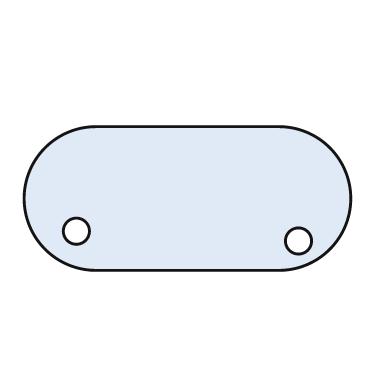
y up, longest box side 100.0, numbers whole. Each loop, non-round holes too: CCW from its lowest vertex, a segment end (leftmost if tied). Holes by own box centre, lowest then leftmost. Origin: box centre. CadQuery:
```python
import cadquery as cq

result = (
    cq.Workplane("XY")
    .moveTo(-28.0, -22.0)
    .lineTo(28.0, -22.0)
    .threePointArc((50.0, 0.0), (28.0, 22.0))
    .lineTo(-28.0, 22.0)
    .threePointArc((-50.0, 0.0), (-28.0, -22.0))
    .close()
    .moveTo(34.0, -13.0)
    .circle(4.0)
    .moveTo(-34.0, -10.0)
    .circle(4.0)
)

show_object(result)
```